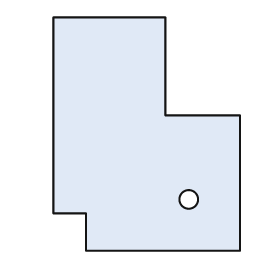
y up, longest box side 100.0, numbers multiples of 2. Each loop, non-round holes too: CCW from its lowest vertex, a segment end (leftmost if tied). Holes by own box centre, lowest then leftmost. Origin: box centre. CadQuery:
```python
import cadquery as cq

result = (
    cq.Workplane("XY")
    .moveTo(-26.0, -50.0)
    .lineTo(40.0, -50.0)
    .lineTo(40.0, 8.0)
    .lineTo(8.0, 8.0)
    .lineTo(8.0, 50.0)
    .lineTo(-40.0, 50.0)
    .lineTo(-40.0, -34.0)
    .lineTo(-26.0, -34.0)
    .close()
    .moveTo(18.0, -28.0)
    .circle(4.0)
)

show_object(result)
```